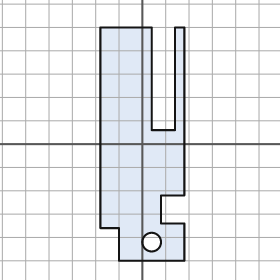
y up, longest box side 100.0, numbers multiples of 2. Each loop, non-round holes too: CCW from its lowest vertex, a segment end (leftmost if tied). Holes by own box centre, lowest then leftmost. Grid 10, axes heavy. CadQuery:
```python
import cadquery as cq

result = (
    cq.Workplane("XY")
    .moveTo(-10.0, -50.0)
    .lineTo(18.0, -50.0)
    .lineTo(18.0, -34.0)
    .lineTo(8.0, -34.0)
    .lineTo(8.0, -22.0)
    .lineTo(18.0, -22.0)
    .lineTo(18.0, 50.0)
    .lineTo(14.0, 50.0)
    .lineTo(14.0, 6.0)
    .lineTo(4.0, 6.0)
    .lineTo(4.0, 50.0)
    .lineTo(-18.0, 50.0)
    .lineTo(-18.0, -36.0)
    .lineTo(-10.0, -36.0)
    .close()
    .moveTo(4.0, -42.0)
    .circle(4.0)
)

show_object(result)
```